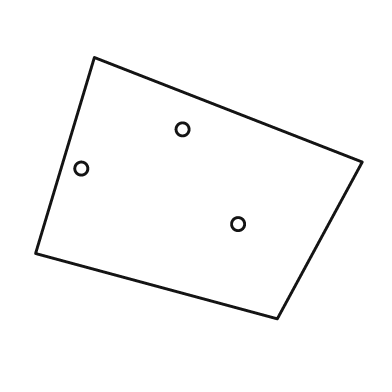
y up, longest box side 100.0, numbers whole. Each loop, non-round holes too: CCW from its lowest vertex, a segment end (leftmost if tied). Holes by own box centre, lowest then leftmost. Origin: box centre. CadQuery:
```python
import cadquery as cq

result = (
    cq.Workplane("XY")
    .moveTo(24.0, -40.0)
    .lineTo(50.0, 8.0)
    .lineTo(-32.0, 40.0)
    .lineTo(-50.0, -20.0)
    .close()
    .moveTo(12.0, -11.0)
    .circle(2.0)
    .moveTo(-36.0, 6.0)
    .circle(2.0)
    .moveTo(-5.0, 18.0)
    .circle(2.0)
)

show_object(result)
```